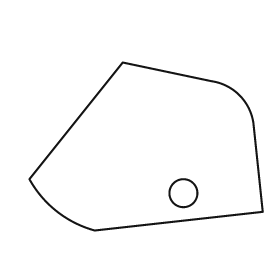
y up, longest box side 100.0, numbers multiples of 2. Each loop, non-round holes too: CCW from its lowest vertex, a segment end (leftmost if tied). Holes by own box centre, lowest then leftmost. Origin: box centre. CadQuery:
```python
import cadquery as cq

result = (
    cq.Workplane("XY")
    .moveTo(-22.0, -36.0)
    .lineTo(50.0, -28.0)
    .lineTo(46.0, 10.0)
    .threePointArc((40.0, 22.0), (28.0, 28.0))
    .lineTo(-10.0, 36.0)
    .lineTo(-50.0, -14.0)
    .threePointArc((-38.0, -28.0), (-22.0, -36.0))
    .close()
    .moveTo(16.0, -20.0)
    .circle(6.0)
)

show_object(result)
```